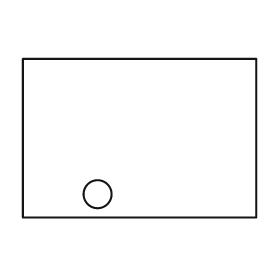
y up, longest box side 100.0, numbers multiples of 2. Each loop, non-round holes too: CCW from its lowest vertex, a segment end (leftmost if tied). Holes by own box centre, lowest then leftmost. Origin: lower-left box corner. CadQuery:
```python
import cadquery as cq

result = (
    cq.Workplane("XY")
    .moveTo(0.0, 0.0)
    .lineTo(100.0, 0.0)
    .lineTo(100.0, 68.0)
    .lineTo(0.0, 68.0)
    .close()
    .moveTo(32.0, 10.0)
    .circle(6.0)
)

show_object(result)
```